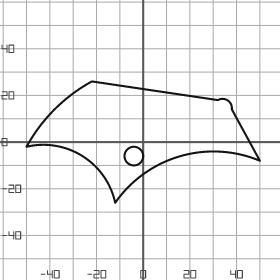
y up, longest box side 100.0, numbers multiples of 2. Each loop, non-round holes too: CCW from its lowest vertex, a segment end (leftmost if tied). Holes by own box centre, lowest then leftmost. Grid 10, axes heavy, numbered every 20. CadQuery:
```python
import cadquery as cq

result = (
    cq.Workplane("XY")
    .moveTo(-12.0, -26.0)
    .threePointArc((16.0, -6.0), (50.0, -8.0))
    .lineTo(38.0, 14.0)
    .threePointArc((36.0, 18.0), (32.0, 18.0))
    .lineTo(-22.0, 26.0)
    .threePointArc((-38.0, 14.0), (-50.0, -2.0))
    .threePointArc((-26.0, -6.0), (-12.0, -26.0))
    .close()
    .moveTo(-4.0, -6.0)
    .circle(4.0)
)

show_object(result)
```